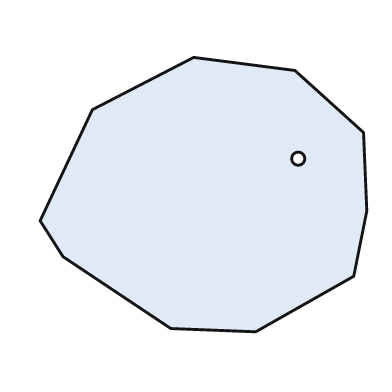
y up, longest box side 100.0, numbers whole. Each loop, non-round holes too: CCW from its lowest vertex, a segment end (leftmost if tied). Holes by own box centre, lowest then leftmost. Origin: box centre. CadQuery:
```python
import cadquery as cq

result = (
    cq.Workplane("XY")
    .moveTo(16.0, -42.0)
    .lineTo(46.0, -25.0)
    .lineTo(50.0, -5.0)
    .lineTo(49.0, 19.0)
    .lineTo(28.0, 38.0)
    .lineTo(-3.0, 42.0)
    .lineTo(-34.0, 26.0)
    .lineTo(-50.0, -8.0)
    .lineTo(-43.0, -19.0)
    .lineTo(-10.0, -41.0)
    .close()
    .moveTo(29.0, 11.0)
    .circle(2.0)
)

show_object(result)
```